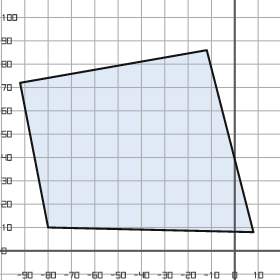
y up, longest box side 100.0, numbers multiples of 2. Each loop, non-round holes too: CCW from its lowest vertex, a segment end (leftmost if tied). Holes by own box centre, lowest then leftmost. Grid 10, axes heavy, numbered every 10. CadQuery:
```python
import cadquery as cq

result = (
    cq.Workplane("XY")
    .moveTo(8.0, 8.0)
    .lineTo(-12.0, 86.0)
    .lineTo(-92.0, 72.0)
    .lineTo(-80.0, 10.0)
    .close()
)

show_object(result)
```